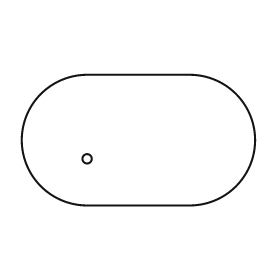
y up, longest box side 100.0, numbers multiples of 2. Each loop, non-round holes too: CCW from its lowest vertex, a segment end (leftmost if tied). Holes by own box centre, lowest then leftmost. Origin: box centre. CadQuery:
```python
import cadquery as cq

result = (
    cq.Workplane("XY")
    .moveTo(-22.0, -28.0)
    .lineTo(22.0, -28.0)
    .threePointArc((50.0, 0.0), (22.0, 28.0))
    .lineTo(-22.0, 28.0)
    .threePointArc((-50.0, 0.0), (-22.0, -28.0))
    .close()
    .moveTo(-22.0, -8.0)
    .circle(2.0)
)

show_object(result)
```